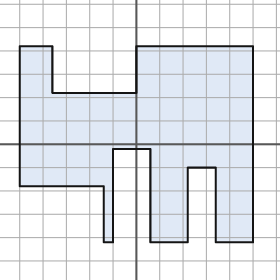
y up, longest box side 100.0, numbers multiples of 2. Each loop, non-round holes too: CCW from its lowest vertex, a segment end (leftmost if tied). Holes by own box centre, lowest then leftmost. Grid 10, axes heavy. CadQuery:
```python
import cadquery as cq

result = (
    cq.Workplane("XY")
    .moveTo(-14.0, -42.0)
    .lineTo(-10.0, -42.0)
    .lineTo(-10.0, -2.0)
    .lineTo(6.0, -2.0)
    .lineTo(6.0, -42.0)
    .lineTo(22.0, -42.0)
    .lineTo(22.0, -10.0)
    .lineTo(34.0, -10.0)
    .lineTo(34.0, -42.0)
    .lineTo(50.0, -42.0)
    .lineTo(50.0, 42.0)
    .lineTo(0.0, 42.0)
    .lineTo(0.0, 22.0)
    .lineTo(-36.0, 22.0)
    .lineTo(-36.0, 42.0)
    .lineTo(-50.0, 42.0)
    .lineTo(-50.0, -18.0)
    .lineTo(-14.0, -18.0)
    .close()
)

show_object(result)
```